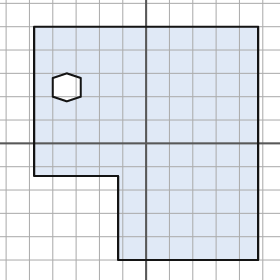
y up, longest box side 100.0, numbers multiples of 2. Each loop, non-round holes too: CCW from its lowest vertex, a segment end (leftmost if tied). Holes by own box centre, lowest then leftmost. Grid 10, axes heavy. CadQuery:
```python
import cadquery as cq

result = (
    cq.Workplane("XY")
    .moveTo(-12.0, -50.0)
    .lineTo(48.0, -50.0)
    .lineTo(48.0, 50.0)
    .lineTo(-48.0, 50.0)
    .lineTo(-48.0, -14.0)
    .lineTo(-12.0, -14.0)
    .close()
    .moveTo(-34.0, 18.0)
    .lineTo(-28.0, 20.0)
    .lineTo(-28.0, 28.0)
    .lineTo(-34.0, 30.0)
    .lineTo(-40.0, 28.0)
    .lineTo(-40.0, 20.0)
    .close()
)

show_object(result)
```